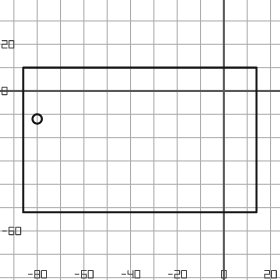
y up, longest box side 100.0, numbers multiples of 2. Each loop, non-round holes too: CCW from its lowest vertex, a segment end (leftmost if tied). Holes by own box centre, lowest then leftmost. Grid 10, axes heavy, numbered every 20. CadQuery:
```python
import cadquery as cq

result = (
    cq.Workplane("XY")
    .moveTo(-86.0, -52.0)
    .lineTo(14.0, -52.0)
    .lineTo(14.0, 10.0)
    .lineTo(-86.0, 10.0)
    .close()
    .moveTo(-80.0, -12.0)
    .circle(2.0)
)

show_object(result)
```